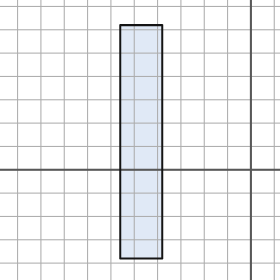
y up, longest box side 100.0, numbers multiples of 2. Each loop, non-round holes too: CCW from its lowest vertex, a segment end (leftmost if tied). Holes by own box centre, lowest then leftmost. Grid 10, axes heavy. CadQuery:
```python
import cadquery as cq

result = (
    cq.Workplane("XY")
    .moveTo(-56.0, -38.0)
    .lineTo(-38.0, -38.0)
    .lineTo(-38.0, 62.0)
    .lineTo(-56.0, 62.0)
    .close()
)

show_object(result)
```